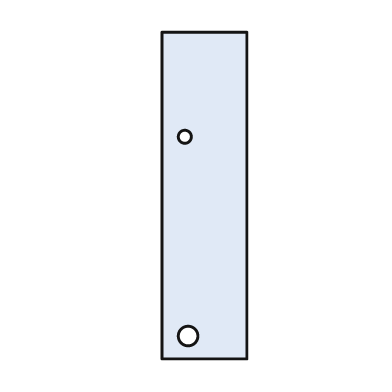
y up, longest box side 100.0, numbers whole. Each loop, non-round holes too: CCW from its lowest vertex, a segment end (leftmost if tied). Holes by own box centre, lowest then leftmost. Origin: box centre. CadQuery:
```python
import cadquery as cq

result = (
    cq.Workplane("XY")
    .moveTo(-13.0, -50.0)
    .lineTo(13.0, -50.0)
    .lineTo(13.0, 50.0)
    .lineTo(-13.0, 50.0)
    .close()
    .moveTo(-5.0, -43.0)
    .circle(3.0)
    .moveTo(-6.0, 18.0)
    .circle(2.0)
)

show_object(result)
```